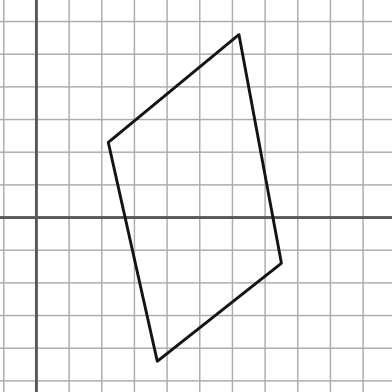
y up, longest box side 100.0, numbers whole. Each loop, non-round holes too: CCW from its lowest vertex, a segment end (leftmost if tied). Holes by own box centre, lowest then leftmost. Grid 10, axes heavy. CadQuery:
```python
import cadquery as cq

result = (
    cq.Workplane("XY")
    .moveTo(37.0, -44.0)
    .lineTo(75.0, -14.0)
    .lineTo(62.0, 56.0)
    .lineTo(22.0, 23.0)
    .close()
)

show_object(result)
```